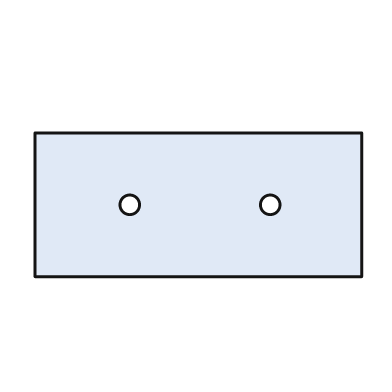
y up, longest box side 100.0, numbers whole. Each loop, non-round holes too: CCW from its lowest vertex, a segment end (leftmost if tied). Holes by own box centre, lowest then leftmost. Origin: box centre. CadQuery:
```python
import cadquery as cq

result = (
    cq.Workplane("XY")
    .moveTo(-50.0, -22.0)
    .lineTo(50.0, -22.0)
    .lineTo(50.0, 22.0)
    .lineTo(-50.0, 22.0)
    .close()
    .moveTo(-21.0, 0.0)
    .circle(3.0)
    .moveTo(22.0, 0.0)
    .circle(3.0)
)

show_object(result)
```